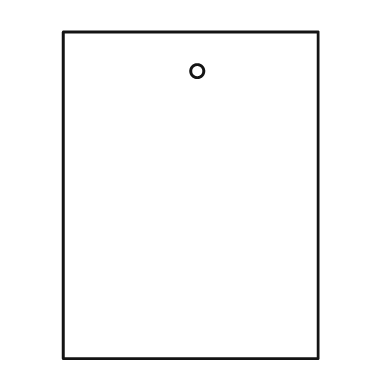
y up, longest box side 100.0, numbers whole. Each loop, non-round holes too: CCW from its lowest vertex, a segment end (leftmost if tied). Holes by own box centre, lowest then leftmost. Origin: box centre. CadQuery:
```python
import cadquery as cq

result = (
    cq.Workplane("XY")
    .moveTo(-39.0, -50.0)
    .lineTo(39.0, -50.0)
    .lineTo(39.0, 50.0)
    .lineTo(-39.0, 50.0)
    .close()
    .moveTo(2.0, 38.0)
    .circle(2.0)
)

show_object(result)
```